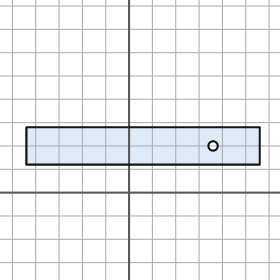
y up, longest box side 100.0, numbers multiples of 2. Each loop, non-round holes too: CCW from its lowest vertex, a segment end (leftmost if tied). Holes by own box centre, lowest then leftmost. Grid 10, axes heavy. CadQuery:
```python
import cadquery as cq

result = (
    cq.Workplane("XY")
    .moveTo(-44.0, 12.0)
    .lineTo(56.0, 12.0)
    .lineTo(56.0, 28.0)
    .lineTo(-44.0, 28.0)
    .close()
    .moveTo(36.0, 20.0)
    .circle(2.0)
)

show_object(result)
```